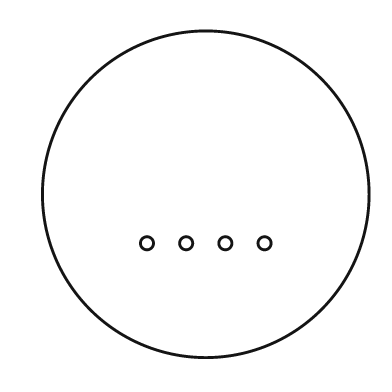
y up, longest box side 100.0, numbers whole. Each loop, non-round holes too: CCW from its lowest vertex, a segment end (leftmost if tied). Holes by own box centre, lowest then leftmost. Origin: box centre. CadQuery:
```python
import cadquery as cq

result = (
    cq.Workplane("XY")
    .moveTo(0.0, 0.0)
    .circle(50.0)
    .moveTo(-18.0, -15.0)
    .circle(2.0)
    .moveTo(-6.0, -15.0)
    .circle(2.0)
    .moveTo(6.0, -15.0)
    .circle(2.0)
    .moveTo(18.0, -15.0)
    .circle(2.0)
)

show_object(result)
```